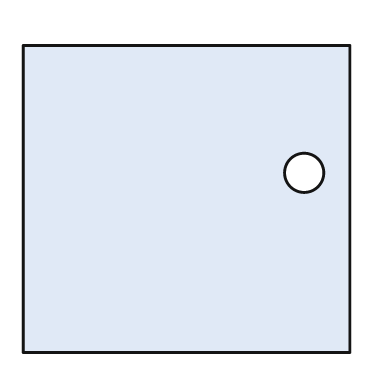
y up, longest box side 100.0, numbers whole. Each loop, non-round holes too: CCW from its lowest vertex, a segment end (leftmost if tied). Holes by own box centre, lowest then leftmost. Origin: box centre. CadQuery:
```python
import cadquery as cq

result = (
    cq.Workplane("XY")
    .moveTo(-50.0, -47.0)
    .lineTo(50.0, -47.0)
    .lineTo(50.0, 47.0)
    .lineTo(-50.0, 47.0)
    .close()
    .moveTo(36.0, 8.0)
    .circle(6.0)
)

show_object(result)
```